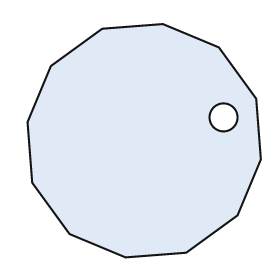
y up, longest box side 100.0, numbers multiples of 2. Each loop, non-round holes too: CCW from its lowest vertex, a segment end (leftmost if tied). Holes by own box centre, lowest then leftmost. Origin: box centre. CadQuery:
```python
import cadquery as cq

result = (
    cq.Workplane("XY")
    .moveTo(-8.0, -50.0)
    .lineTo(18.0, -48.0)
    .lineTo(40.0, -32.0)
    .lineTo(50.0, -8.0)
    .lineTo(48.0, 18.0)
    .lineTo(32.0, 40.0)
    .lineTo(8.0, 50.0)
    .lineTo(-18.0, 48.0)
    .lineTo(-40.0, 32.0)
    .lineTo(-50.0, 8.0)
    .lineTo(-48.0, -18.0)
    .lineTo(-32.0, -40.0)
    .close()
    .moveTo(34.0, 10.0)
    .circle(6.0)
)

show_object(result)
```